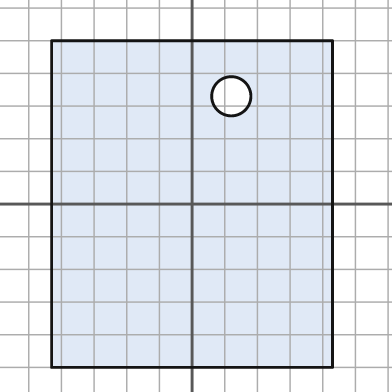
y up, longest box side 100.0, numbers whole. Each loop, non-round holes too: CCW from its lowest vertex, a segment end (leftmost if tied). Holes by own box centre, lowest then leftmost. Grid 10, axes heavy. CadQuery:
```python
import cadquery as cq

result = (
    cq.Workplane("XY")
    .moveTo(-43.0, -50.0)
    .lineTo(43.0, -50.0)
    .lineTo(43.0, 50.0)
    .lineTo(-43.0, 50.0)
    .close()
    .moveTo(12.0, 33.0)
    .circle(6.0)
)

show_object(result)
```